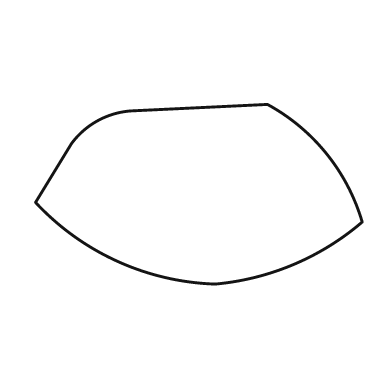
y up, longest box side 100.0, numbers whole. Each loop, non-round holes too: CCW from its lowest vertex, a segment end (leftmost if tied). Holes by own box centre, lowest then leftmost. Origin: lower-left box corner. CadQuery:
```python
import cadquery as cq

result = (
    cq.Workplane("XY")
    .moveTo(55.0, 0.0)
    .threePointArc((79.0, 6.0), (100.0, 19.0))
    .threePointArc((89.0, 40.0), (71.0, 55.0))
    .lineTo(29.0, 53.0)
    .threePointArc((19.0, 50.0), (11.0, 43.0))
    .lineTo(0.0, 25.0)
    .threePointArc((25.0, 7.0), (55.0, 0.0))
    .close()
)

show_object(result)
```